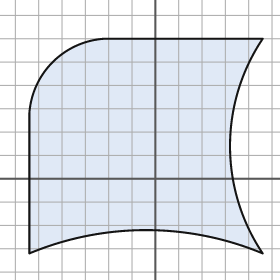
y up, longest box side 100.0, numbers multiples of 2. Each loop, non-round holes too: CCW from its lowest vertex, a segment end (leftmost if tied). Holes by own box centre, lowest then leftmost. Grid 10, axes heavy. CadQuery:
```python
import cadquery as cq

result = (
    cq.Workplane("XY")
    .moveTo(-54.0, -32.0)
    .threePointArc((-4.0, -22.0), (46.0, -32.0))
    .threePointArc((32.0, 14.0), (46.0, 60.0))
    .lineTo(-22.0, 60.0)
    .threePointArc((-44.0, 50.0), (-54.0, 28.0))
    .close()
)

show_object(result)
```